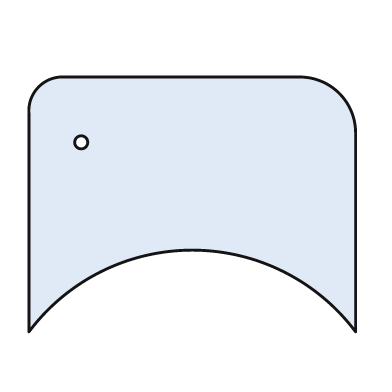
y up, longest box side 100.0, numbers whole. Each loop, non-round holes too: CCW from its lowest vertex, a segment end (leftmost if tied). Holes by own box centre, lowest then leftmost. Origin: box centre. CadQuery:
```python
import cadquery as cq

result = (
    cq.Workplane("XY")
    .moveTo(-50.0, -39.0)
    .threePointArc((0.0, -14.0), (50.0, -39.0))
    .lineTo(50.0, 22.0)
    .threePointArc((45.0, 34.0), (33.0, 39.0))
    .lineTo(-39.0, 39.0)
    .threePointArc((-47.0, 36.0), (-50.0, 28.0))
    .close()
    .moveTo(-34.0, 19.0)
    .circle(2.0)
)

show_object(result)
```